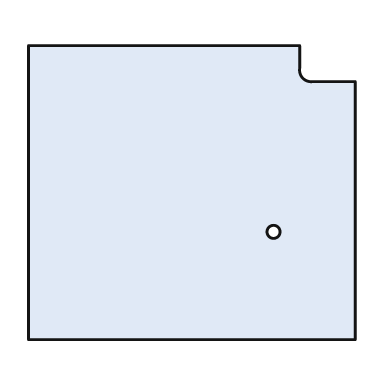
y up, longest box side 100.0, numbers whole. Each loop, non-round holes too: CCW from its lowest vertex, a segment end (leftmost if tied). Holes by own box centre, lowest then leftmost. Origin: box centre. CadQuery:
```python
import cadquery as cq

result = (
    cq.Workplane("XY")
    .moveTo(-50.0, -45.0)
    .lineTo(50.0, -45.0)
    .lineTo(50.0, 34.0)
    .lineTo(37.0, 34.0)
    .threePointArc((34.0, 35.0), (33.0, 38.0))
    .lineTo(33.0, 45.0)
    .lineTo(-50.0, 45.0)
    .close()
    .moveTo(25.0, -12.0)
    .circle(2.0)
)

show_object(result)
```